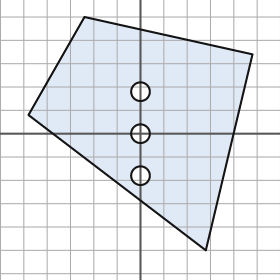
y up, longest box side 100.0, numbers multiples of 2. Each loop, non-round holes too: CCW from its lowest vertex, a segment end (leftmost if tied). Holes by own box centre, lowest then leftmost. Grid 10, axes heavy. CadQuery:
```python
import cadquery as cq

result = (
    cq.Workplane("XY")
    .moveTo(28.0, -50.0)
    .lineTo(48.0, 34.0)
    .lineTo(-24.0, 50.0)
    .lineTo(-48.0, 8.0)
    .close()
    .moveTo(0.0, -18.0)
    .circle(4.0)
    .moveTo(0.0, 0.0)
    .circle(4.0)
    .moveTo(0.0, 18.0)
    .circle(4.0)
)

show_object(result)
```